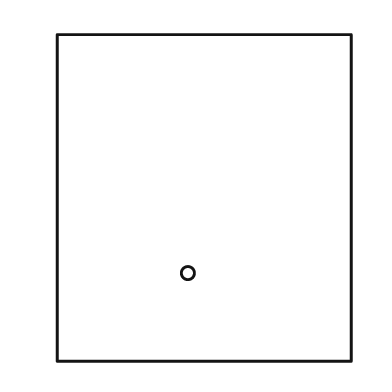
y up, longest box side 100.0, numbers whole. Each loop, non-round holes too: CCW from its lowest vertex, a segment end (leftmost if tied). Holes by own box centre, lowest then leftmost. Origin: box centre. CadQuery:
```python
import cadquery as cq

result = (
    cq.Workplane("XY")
    .moveTo(-45.0, -50.0)
    .lineTo(45.0, -50.0)
    .lineTo(45.0, 50.0)
    .lineTo(-45.0, 50.0)
    .close()
    .moveTo(-5.0, -23.0)
    .circle(2.0)
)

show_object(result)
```